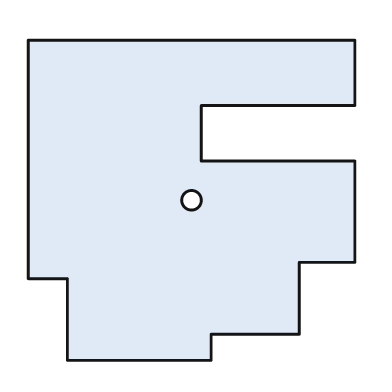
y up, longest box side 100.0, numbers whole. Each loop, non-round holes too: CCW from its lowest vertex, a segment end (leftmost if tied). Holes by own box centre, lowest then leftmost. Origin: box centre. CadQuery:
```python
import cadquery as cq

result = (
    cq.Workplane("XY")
    .moveTo(-38.0, -49.0)
    .lineTo(6.0, -49.0)
    .lineTo(6.0, -41.0)
    .lineTo(33.0, -41.0)
    .lineTo(33.0, -19.0)
    .lineTo(50.0, -19.0)
    .lineTo(50.0, 12.0)
    .lineTo(3.0, 12.0)
    .lineTo(3.0, 29.0)
    .lineTo(50.0, 29.0)
    .lineTo(50.0, 49.0)
    .lineTo(-50.0, 49.0)
    .lineTo(-50.0, -24.0)
    .lineTo(-38.0, -24.0)
    .close()
    .moveTo(0.0, 0.0)
    .circle(3.0)
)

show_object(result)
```